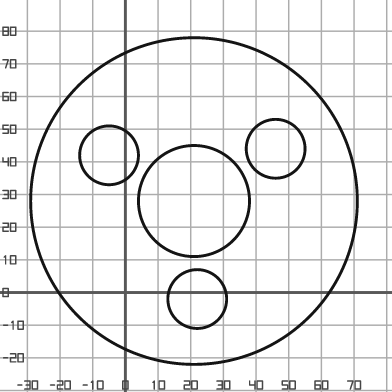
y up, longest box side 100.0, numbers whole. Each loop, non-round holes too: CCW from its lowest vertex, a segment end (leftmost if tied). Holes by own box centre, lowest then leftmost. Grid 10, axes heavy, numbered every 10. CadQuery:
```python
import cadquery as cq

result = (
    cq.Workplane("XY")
    .moveTo(21.0, 28.0)
    .circle(50.0)
    .moveTo(22.0, -2.0)
    .circle(9.0)
    .moveTo(21.0, 28.0)
    .circle(17.0)
    .moveTo(-5.0, 42.0)
    .circle(9.0)
    .moveTo(46.0, 44.0)
    .circle(9.0)
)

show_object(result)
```